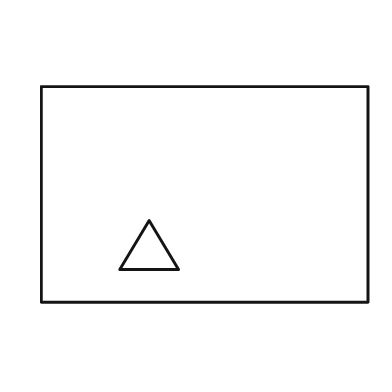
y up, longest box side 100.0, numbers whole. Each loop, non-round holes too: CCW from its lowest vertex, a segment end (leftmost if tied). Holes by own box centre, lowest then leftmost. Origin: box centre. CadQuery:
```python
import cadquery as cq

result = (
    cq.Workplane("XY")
    .moveTo(-50.0, -33.0)
    .lineTo(50.0, -33.0)
    .lineTo(50.0, 33.0)
    .lineTo(-50.0, 33.0)
    .close()
    .moveTo(-26.0, -23.0)
    .lineTo(-8.0, -23.0)
    .lineTo(-17.0, -8.0)
    .close()
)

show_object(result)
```